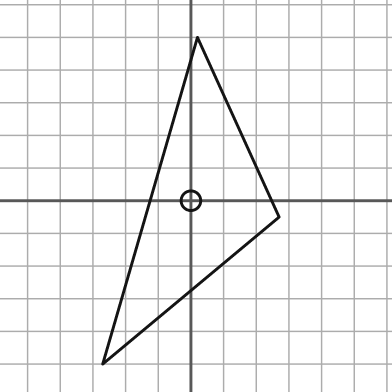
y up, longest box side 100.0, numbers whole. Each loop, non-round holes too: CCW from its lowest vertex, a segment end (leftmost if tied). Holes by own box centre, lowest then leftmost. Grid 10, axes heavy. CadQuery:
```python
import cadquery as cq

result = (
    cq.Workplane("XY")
    .moveTo(-27.0, -50.0)
    .lineTo(27.0, -5.0)
    .lineTo(2.0, 50.0)
    .close()
    .moveTo(0.0, 0.0)
    .circle(3.0)
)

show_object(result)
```